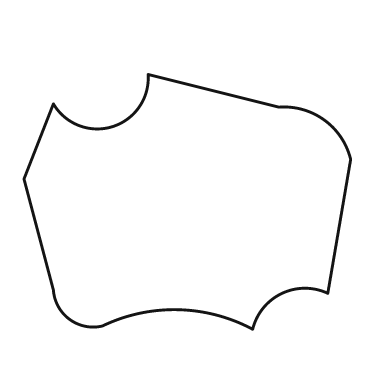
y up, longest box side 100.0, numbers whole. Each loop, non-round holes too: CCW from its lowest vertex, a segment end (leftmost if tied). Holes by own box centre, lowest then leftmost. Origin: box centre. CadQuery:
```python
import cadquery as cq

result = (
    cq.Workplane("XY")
    .moveTo(20.0, -39.0)
    .threePointArc((29.0, -28.0), (43.0, -28.0))
    .lineTo(50.0, 13.0)
    .threePointArc((42.0, 25.0), (28.0, 29.0))
    .lineTo(-12.0, 39.0)
    .threePointArc((-23.0, 23.0), (-41.0, 30.0))
    .lineTo(-50.0, 7.0)
    .lineTo(-41.0, -27.0)
    .threePointArc((-36.0, -36.0), (-26.0, -38.0))
    .threePointArc((-3.0, -33.0), (20.0, -39.0))
    .close()
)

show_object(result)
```